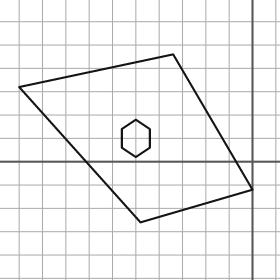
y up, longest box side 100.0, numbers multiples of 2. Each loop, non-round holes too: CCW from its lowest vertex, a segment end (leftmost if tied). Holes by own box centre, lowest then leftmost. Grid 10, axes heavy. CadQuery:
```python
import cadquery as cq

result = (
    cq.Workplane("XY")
    .moveTo(-48.0, -26.0)
    .lineTo(0.0, -12.0)
    .lineTo(-34.0, 46.0)
    .lineTo(-100.0, 32.0)
    .close()
    .moveTo(-50.0, 2.0)
    .lineTo(-44.0, 6.0)
    .lineTo(-44.0, 14.0)
    .lineTo(-50.0, 18.0)
    .lineTo(-56.0, 14.0)
    .lineTo(-56.0, 6.0)
    .close()
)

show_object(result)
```